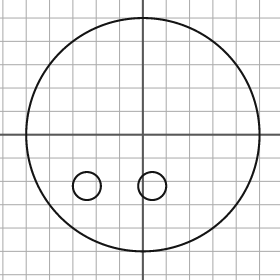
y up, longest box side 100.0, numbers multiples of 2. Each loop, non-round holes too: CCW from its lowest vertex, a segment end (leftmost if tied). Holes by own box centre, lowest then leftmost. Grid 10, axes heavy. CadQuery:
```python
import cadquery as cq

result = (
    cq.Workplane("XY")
    .moveTo(0.0, 0.0)
    .circle(50.0)
    .moveTo(-24.0, -22.0)
    .circle(6.0)
    .moveTo(4.0, -22.0)
    .circle(6.0)
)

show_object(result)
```